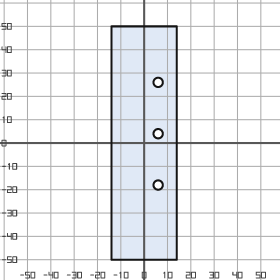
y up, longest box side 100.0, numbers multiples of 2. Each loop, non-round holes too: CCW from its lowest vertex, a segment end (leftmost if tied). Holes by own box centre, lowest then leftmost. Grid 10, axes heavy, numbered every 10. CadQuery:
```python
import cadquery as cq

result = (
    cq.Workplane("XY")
    .moveTo(-14.0, -50.0)
    .lineTo(14.0, -50.0)
    .lineTo(14.0, 50.0)
    .lineTo(-14.0, 50.0)
    .close()
    .moveTo(6.0, -18.0)
    .circle(2.0)
    .moveTo(6.0, 4.0)
    .circle(2.0)
    .moveTo(6.0, 26.0)
    .circle(2.0)
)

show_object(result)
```